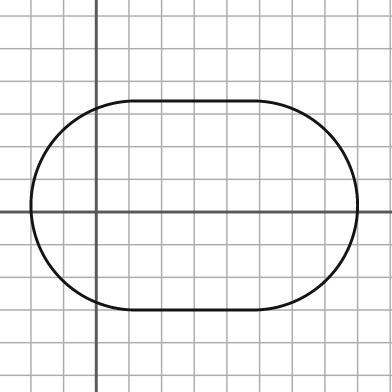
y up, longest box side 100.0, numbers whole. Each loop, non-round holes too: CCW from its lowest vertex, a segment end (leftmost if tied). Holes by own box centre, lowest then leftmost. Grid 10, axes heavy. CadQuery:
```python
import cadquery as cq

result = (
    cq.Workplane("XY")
    .moveTo(12.0, -30.0)
    .lineTo(48.0, -30.0)
    .threePointArc((80.0, 2.0), (48.0, 34.0))
    .lineTo(12.0, 34.0)
    .threePointArc((-20.0, 2.0), (12.0, -30.0))
    .close()
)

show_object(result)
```